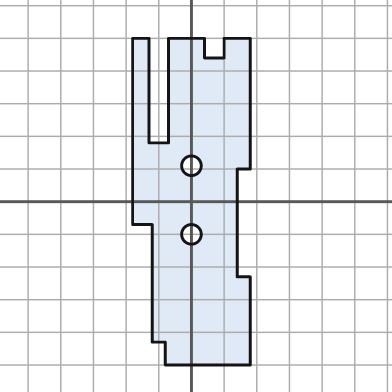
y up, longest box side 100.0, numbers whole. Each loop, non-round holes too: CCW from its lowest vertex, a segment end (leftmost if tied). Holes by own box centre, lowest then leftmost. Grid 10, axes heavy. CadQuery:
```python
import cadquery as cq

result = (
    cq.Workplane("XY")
    .moveTo(-8.0, -50.0)
    .lineTo(18.0, -50.0)
    .lineTo(18.0, -23.0)
    .lineTo(14.0, -23.0)
    .lineTo(14.0, 10.0)
    .lineTo(18.0, 10.0)
    .lineTo(18.0, 50.0)
    .lineTo(10.0, 50.0)
    .lineTo(10.0, 44.0)
    .lineTo(4.0, 44.0)
    .lineTo(4.0, 50.0)
    .lineTo(-7.0, 50.0)
    .lineTo(-7.0, 18.0)
    .lineTo(-13.0, 18.0)
    .lineTo(-13.0, 50.0)
    .lineTo(-18.0, 50.0)
    .lineTo(-18.0, -7.0)
    .lineTo(-12.0, -7.0)
    .lineTo(-12.0, -43.0)
    .lineTo(-8.0, -43.0)
    .close()
    .moveTo(0.0, -10.0)
    .circle(3.0)
    .moveTo(0.0, 11.0)
    .circle(3.0)
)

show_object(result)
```